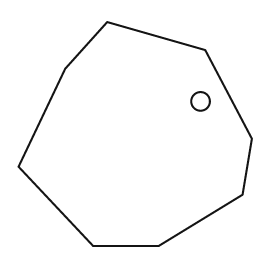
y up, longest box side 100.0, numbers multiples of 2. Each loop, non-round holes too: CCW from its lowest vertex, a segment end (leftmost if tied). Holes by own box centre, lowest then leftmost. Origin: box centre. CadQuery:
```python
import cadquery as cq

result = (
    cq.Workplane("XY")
    .moveTo(-18.0, -48.0)
    .lineTo(10.0, -48.0)
    .lineTo(46.0, -26.0)
    .lineTo(50.0, -2.0)
    .lineTo(30.0, 36.0)
    .lineTo(-12.0, 48.0)
    .lineTo(-30.0, 28.0)
    .lineTo(-50.0, -14.0)
    .close()
    .moveTo(28.0, 14.0)
    .circle(4.0)
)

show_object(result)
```